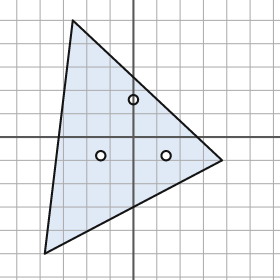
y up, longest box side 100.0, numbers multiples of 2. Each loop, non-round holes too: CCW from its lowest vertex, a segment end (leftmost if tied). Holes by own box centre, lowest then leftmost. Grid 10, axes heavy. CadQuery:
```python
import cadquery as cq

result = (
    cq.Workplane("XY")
    .moveTo(-38.0, -50.0)
    .lineTo(38.0, -10.0)
    .lineTo(-26.0, 50.0)
    .close()
    .moveTo(-14.0, -8.0)
    .circle(2.0)
    .moveTo(14.0, -8.0)
    .circle(2.0)
    .moveTo(0.0, 16.0)
    .circle(2.0)
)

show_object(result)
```